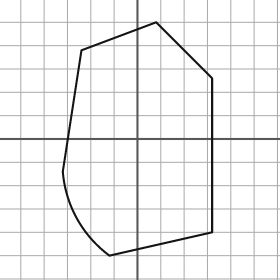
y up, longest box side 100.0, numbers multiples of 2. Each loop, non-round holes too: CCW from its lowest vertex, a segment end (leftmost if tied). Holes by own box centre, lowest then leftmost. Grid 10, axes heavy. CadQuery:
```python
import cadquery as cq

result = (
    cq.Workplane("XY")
    .moveTo(-12.0, -50.0)
    .lineTo(32.0, -40.0)
    .lineTo(32.0, 26.0)
    .lineTo(8.0, 50.0)
    .lineTo(-24.0, 38.0)
    .lineTo(-32.0, -14.0)
    .threePointArc((-26.0, -34.0), (-12.0, -50.0))
    .close()
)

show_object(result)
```